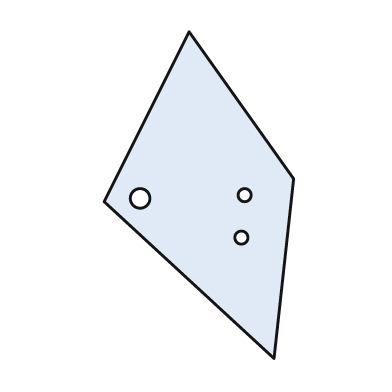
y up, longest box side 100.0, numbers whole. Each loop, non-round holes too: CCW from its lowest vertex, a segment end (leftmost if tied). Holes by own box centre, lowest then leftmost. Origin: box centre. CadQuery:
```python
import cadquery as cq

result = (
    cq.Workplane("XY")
    .moveTo(23.0, -50.0)
    .lineTo(29.0, 5.0)
    .lineTo(-3.0, 50.0)
    .lineTo(-29.0, -2.0)
    .close()
    .moveTo(13.0, -13.0)
    .circle(2.0)
    .moveTo(-18.0, -1.0)
    .circle(3.0)
    .moveTo(14.0, 0.0)
    .circle(2.0)
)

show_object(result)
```